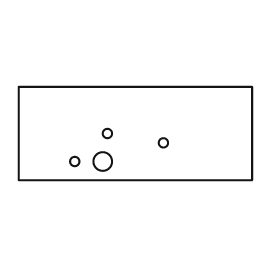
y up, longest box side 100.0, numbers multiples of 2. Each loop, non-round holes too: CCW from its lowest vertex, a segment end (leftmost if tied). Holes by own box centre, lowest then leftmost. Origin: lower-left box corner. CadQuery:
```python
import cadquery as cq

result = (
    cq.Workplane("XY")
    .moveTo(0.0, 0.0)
    .lineTo(100.0, 0.0)
    .lineTo(100.0, 40.0)
    .lineTo(0.0, 40.0)
    .close()
    .moveTo(24.0, 8.0)
    .circle(2.0)
    .moveTo(36.0, 8.0)
    .circle(4.0)
    .moveTo(62.0, 16.0)
    .circle(2.0)
    .moveTo(38.0, 20.0)
    .circle(2.0)
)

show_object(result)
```